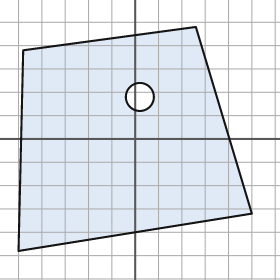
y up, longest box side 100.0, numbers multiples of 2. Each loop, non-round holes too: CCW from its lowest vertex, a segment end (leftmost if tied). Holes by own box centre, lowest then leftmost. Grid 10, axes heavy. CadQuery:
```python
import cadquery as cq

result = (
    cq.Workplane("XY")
    .moveTo(-50.0, -48.0)
    .lineTo(50.0, -32.0)
    .lineTo(26.0, 48.0)
    .lineTo(-48.0, 38.0)
    .close()
    .moveTo(2.0, 18.0)
    .circle(6.0)
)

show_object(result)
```